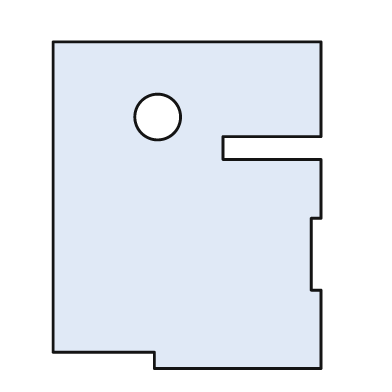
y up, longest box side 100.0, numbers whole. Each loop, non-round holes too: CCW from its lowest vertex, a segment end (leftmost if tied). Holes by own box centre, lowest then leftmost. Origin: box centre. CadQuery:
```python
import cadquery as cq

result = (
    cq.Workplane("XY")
    .moveTo(-10.0, -50.0)
    .lineTo(41.0, -50.0)
    .lineTo(41.0, -26.0)
    .lineTo(38.0, -26.0)
    .lineTo(38.0, -4.0)
    .lineTo(41.0, -4.0)
    .lineTo(41.0, 14.0)
    .lineTo(11.0, 14.0)
    .lineTo(11.0, 21.0)
    .lineTo(41.0, 21.0)
    .lineTo(41.0, 50.0)
    .lineTo(-41.0, 50.0)
    .lineTo(-41.0, -45.0)
    .lineTo(-10.0, -45.0)
    .close()
    .moveTo(-9.0, 27.0)
    .circle(7.0)
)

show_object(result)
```